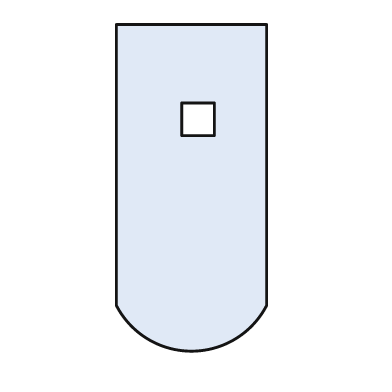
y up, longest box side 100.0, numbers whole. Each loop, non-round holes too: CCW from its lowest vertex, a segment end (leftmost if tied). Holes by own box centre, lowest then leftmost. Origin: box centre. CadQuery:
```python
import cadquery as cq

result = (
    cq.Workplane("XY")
    .moveTo(-23.0, -36.0)
    .threePointArc((0.0, -50.0), (23.0, -36.0))
    .lineTo(23.0, 50.0)
    .lineTo(-23.0, 50.0)
    .close()
    .moveTo(-3.0, 16.0)
    .lineTo(7.0, 16.0)
    .lineTo(7.0, 26.0)
    .lineTo(-3.0, 26.0)
    .close()
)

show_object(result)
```